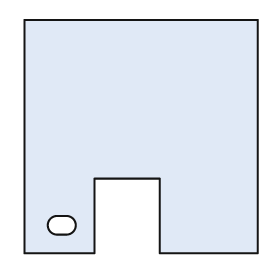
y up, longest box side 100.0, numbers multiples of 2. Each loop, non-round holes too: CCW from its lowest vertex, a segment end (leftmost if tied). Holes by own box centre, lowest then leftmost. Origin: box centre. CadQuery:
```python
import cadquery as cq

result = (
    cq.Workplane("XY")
    .moveTo(-50.0, -50.0)
    .lineTo(-20.0, -50.0)
    .lineTo(-20.0, -18.0)
    .lineTo(8.0, -18.0)
    .lineTo(8.0, -50.0)
    .lineTo(50.0, -50.0)
    .lineTo(50.0, 50.0)
    .lineTo(-50.0, 50.0)
    .close()
    .moveTo(-36.0, -42.0)
    .lineTo(-32.0, -42.0)
    .threePointArc((-28.0, -38.0), (-32.0, -34.0))
    .lineTo(-36.0, -34.0)
    .threePointArc((-40.0, -38.0), (-36.0, -42.0))
    .close()
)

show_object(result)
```